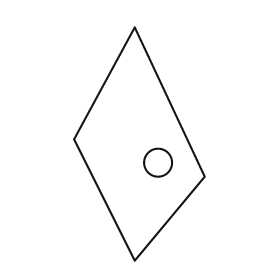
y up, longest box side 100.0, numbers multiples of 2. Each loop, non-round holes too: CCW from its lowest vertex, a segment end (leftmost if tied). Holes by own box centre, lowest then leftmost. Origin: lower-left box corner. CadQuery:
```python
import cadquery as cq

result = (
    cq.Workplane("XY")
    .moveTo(26.0, 0.0)
    .lineTo(56.0, 36.0)
    .lineTo(26.0, 100.0)
    .lineTo(0.0, 52.0)
    .close()
    .moveTo(36.0, 42.0)
    .circle(6.0)
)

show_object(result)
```